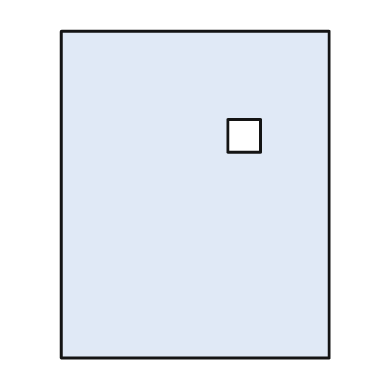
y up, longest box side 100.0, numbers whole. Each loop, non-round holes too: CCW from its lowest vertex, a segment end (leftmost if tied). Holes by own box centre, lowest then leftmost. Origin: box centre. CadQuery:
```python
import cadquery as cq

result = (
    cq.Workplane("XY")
    .moveTo(-41.0, -50.0)
    .lineTo(41.0, -50.0)
    .lineTo(41.0, 50.0)
    .lineTo(-41.0, 50.0)
    .close()
    .moveTo(10.0, 13.0)
    .lineTo(20.0, 13.0)
    .lineTo(20.0, 23.0)
    .lineTo(10.0, 23.0)
    .close()
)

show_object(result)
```